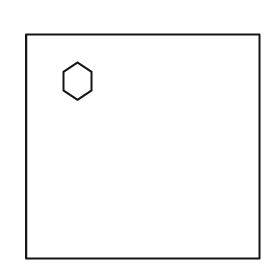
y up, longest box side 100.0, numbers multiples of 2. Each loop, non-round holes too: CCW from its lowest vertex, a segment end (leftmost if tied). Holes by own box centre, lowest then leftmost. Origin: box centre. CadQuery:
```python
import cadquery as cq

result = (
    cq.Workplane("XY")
    .moveTo(-50.0, -48.0)
    .lineTo(50.0, -48.0)
    .lineTo(50.0, 48.0)
    .lineTo(-50.0, 48.0)
    .close()
    .moveTo(-28.0, 20.0)
    .lineTo(-22.0, 24.0)
    .lineTo(-22.0, 32.0)
    .lineTo(-28.0, 36.0)
    .lineTo(-34.0, 32.0)
    .lineTo(-34.0, 24.0)
    .close()
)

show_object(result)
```